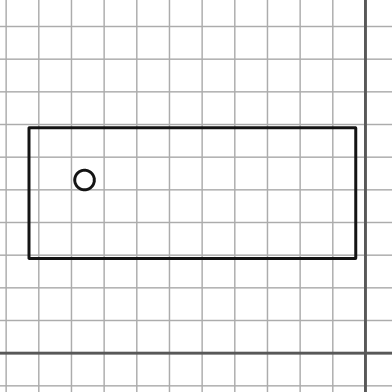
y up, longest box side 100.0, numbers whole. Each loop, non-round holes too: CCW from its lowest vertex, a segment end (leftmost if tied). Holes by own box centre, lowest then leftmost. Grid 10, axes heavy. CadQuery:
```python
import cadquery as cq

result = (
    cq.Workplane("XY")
    .moveTo(-103.0, 29.0)
    .lineTo(-3.0, 29.0)
    .lineTo(-3.0, 69.0)
    .lineTo(-103.0, 69.0)
    .close()
    .moveTo(-86.0, 53.0)
    .circle(3.0)
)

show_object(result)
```